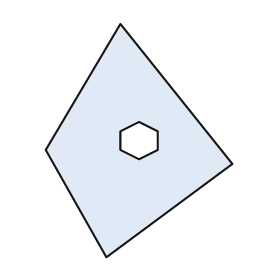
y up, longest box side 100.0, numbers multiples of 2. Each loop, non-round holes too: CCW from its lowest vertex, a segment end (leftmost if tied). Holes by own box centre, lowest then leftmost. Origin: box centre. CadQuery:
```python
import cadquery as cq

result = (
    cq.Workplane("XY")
    .moveTo(-14.0, -50.0)
    .lineTo(40.0, -10.0)
    .lineTo(-8.0, 50.0)
    .lineTo(-40.0, -4.0)
    .close()
    .moveTo(0.0, -8.0)
    .lineTo(8.0, -4.0)
    .lineTo(8.0, 4.0)
    .lineTo(0.0, 8.0)
    .lineTo(-8.0, 4.0)
    .lineTo(-8.0, -4.0)
    .close()
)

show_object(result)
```